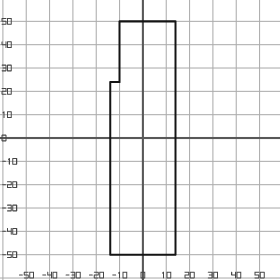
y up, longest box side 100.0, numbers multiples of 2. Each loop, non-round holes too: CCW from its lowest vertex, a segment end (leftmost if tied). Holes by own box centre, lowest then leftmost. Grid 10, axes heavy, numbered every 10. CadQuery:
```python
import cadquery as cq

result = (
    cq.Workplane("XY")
    .moveTo(-14.0, -50.0)
    .lineTo(14.0, -50.0)
    .lineTo(14.0, 50.0)
    .lineTo(-10.0, 50.0)
    .lineTo(-10.0, 24.0)
    .lineTo(-14.0, 24.0)
    .close()
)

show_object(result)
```